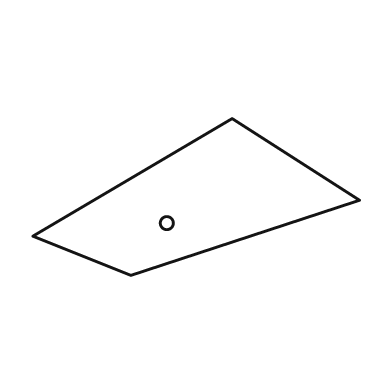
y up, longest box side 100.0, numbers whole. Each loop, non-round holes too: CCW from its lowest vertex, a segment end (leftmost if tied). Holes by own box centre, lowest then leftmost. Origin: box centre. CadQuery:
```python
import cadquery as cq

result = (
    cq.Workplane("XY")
    .moveTo(-20.0, -24.0)
    .lineTo(50.0, -1.0)
    .lineTo(11.0, 24.0)
    .lineTo(-50.0, -12.0)
    .close()
    .moveTo(-9.0, -8.0)
    .circle(2.0)
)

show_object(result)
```